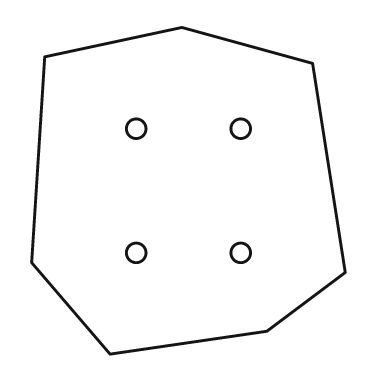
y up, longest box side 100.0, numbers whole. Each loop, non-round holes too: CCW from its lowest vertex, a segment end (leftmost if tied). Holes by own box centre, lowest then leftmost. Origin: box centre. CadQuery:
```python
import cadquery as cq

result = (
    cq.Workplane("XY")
    .moveTo(-24.0, -50.0)
    .lineTo(24.0, -43.0)
    .lineTo(48.0, -25.0)
    .lineTo(38.0, 39.0)
    .lineTo(-2.0, 50.0)
    .lineTo(-44.0, 41.0)
    .lineTo(-48.0, -22.0)
    .close()
    .moveTo(-16.0, -19.0)
    .circle(3.0)
    .moveTo(16.0, -19.0)
    .circle(3.0)
    .moveTo(-16.0, 19.0)
    .circle(3.0)
    .moveTo(16.0, 19.0)
    .circle(3.0)
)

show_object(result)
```